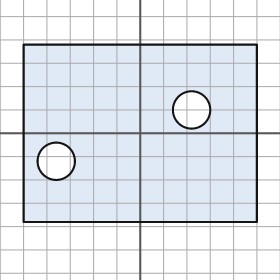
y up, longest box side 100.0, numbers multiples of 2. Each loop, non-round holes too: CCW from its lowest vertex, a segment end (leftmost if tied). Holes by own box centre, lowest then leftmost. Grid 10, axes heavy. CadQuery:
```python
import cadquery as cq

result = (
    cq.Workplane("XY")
    .moveTo(-50.0, -38.0)
    .lineTo(50.0, -38.0)
    .lineTo(50.0, 38.0)
    .lineTo(-50.0, 38.0)
    .close()
    .moveTo(-36.0, -12.0)
    .circle(8.0)
    .moveTo(22.0, 10.0)
    .circle(8.0)
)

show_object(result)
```